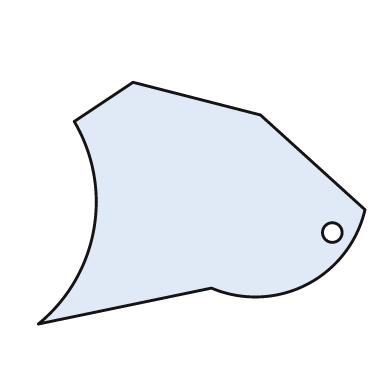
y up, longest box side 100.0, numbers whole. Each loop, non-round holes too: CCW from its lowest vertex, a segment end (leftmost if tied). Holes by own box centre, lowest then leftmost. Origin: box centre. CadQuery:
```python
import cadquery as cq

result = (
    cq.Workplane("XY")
    .moveTo(-50.0, -37.0)
    .lineTo(3.0, -26.0)
    .threePointArc((32.0, -25.0), (50.0, -2.0))
    .lineTo(18.0, 27.0)
    .lineTo(-21.0, 37.0)
    .lineTo(-39.0, 25.0)
    .threePointArc((-33.0, -8.0), (-50.0, -37.0))
    .close()
    .moveTo(40.0, -9.0)
    .circle(3.0)
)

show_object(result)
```